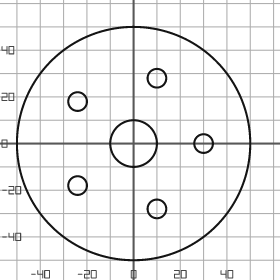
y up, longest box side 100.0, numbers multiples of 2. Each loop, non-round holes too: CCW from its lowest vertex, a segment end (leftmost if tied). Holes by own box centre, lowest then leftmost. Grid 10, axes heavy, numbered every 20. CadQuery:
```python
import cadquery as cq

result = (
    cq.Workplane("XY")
    .moveTo(0.0, 0.0)
    .circle(50.0)
    .moveTo(10.0, -28.0)
    .circle(4.0)
    .moveTo(-24.0, -18.0)
    .circle(4.0)
    .moveTo(0.0, 0.0)
    .circle(10.0)
    .moveTo(30.0, 0.0)
    .circle(4.0)
    .moveTo(-24.0, 18.0)
    .circle(4.0)
    .moveTo(10.0, 28.0)
    .circle(4.0)
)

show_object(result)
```